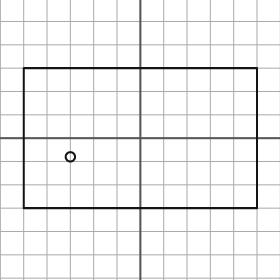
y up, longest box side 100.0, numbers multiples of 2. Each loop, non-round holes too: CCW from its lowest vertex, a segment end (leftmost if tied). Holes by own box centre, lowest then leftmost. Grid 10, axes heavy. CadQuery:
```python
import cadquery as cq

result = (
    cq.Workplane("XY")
    .moveTo(-50.0, -30.0)
    .lineTo(50.0, -30.0)
    .lineTo(50.0, 30.0)
    .lineTo(-50.0, 30.0)
    .close()
    .moveTo(-30.0, -8.0)
    .circle(2.0)
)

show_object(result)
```